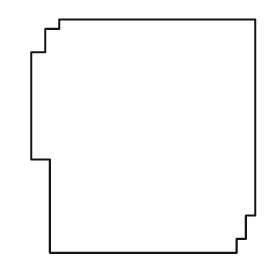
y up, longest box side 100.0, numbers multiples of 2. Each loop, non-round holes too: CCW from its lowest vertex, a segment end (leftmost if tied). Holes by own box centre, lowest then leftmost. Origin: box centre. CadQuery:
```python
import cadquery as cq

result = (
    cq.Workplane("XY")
    .moveTo(-40.0, -50.0)
    .lineTo(40.0, -50.0)
    .lineTo(40.0, -44.0)
    .lineTo(44.0, -44.0)
    .lineTo(44.0, -34.0)
    .lineTo(48.0, -34.0)
    .lineTo(48.0, 50.0)
    .lineTo(-36.0, 50.0)
    .lineTo(-36.0, 46.0)
    .lineTo(-42.0, 46.0)
    .lineTo(-42.0, 36.0)
    .lineTo(-48.0, 36.0)
    .lineTo(-48.0, -10.0)
    .lineTo(-40.0, -10.0)
    .close()
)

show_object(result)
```